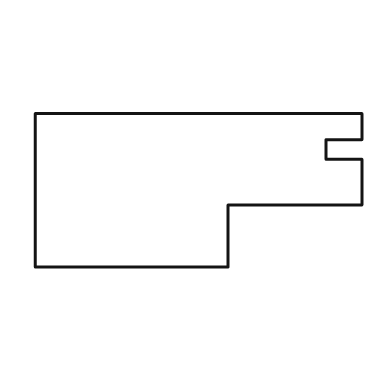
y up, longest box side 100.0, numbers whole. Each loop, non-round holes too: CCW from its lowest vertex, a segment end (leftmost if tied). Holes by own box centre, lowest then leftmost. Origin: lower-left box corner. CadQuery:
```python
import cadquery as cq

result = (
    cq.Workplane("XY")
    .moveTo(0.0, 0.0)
    .lineTo(59.0, 0.0)
    .lineTo(59.0, 19.0)
    .lineTo(100.0, 19.0)
    .lineTo(100.0, 33.0)
    .lineTo(89.0, 33.0)
    .lineTo(89.0, 39.0)
    .lineTo(100.0, 39.0)
    .lineTo(100.0, 47.0)
    .lineTo(0.0, 47.0)
    .close()
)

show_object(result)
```